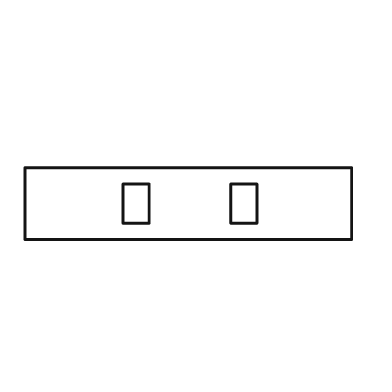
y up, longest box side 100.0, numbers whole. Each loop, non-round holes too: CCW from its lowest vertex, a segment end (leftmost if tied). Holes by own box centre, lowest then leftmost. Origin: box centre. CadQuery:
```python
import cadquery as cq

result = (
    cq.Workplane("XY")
    .moveTo(-50.0, -11.0)
    .lineTo(50.0, -11.0)
    .lineTo(50.0, 11.0)
    .lineTo(-50.0, 11.0)
    .close()
    .moveTo(-20.0, -6.0)
    .lineTo(-12.0, -6.0)
    .lineTo(-12.0, 6.0)
    .lineTo(-20.0, 6.0)
    .close()
    .moveTo(13.0, -6.0)
    .lineTo(21.0, -6.0)
    .lineTo(21.0, 6.0)
    .lineTo(13.0, 6.0)
    .close()
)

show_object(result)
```